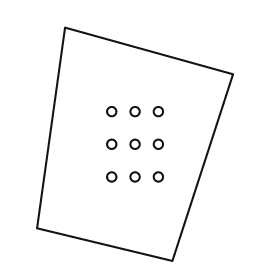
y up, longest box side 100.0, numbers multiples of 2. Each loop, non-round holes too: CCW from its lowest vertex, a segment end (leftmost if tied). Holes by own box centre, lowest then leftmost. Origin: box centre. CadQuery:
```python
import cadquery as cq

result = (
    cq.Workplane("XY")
    .moveTo(16.0, -50.0)
    .lineTo(42.0, 30.0)
    .lineTo(-30.0, 50.0)
    .lineTo(-42.0, -36.0)
    .close()
    .moveTo(-10.0, -14.0)
    .circle(2.0)
    .moveTo(0.0, -14.0)
    .circle(2.0)
    .moveTo(10.0, -14.0)
    .circle(2.0)
    .moveTo(-10.0, 0.0)
    .circle(2.0)
    .moveTo(0.0, 0.0)
    .circle(2.0)
    .moveTo(10.0, 0.0)
    .circle(2.0)
    .moveTo(-10.0, 14.0)
    .circle(2.0)
    .moveTo(0.0, 14.0)
    .circle(2.0)
    .moveTo(10.0, 14.0)
    .circle(2.0)
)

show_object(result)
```